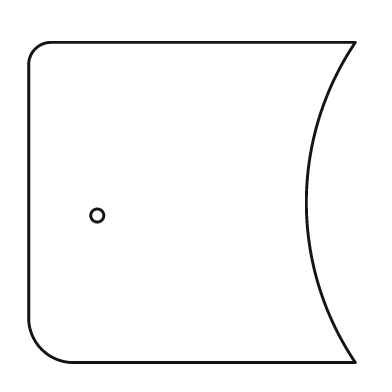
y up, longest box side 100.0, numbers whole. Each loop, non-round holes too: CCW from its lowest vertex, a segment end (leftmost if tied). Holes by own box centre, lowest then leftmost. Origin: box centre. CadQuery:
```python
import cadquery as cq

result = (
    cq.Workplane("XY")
    .moveTo(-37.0, -49.0)
    .lineTo(50.0, -49.0)
    .threePointArc((35.0, 0.0), (50.0, 49.0))
    .lineTo(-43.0, 49.0)
    .threePointArc((-48.0, 47.0), (-50.0, 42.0))
    .lineTo(-50.0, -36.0)
    .threePointArc((-46.0, -45.0), (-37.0, -49.0))
    .close()
    .moveTo(-29.0, -4.0)
    .circle(2.0)
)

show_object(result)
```